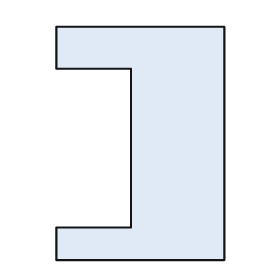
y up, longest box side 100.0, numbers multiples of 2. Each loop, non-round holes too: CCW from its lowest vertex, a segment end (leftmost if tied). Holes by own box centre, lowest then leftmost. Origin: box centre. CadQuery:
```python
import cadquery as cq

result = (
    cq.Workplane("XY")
    .moveTo(-36.0, -50.0)
    .lineTo(36.0, -50.0)
    .lineTo(36.0, 50.0)
    .lineTo(-36.0, 50.0)
    .lineTo(-36.0, 32.0)
    .lineTo(-4.0, 32.0)
    .lineTo(-4.0, -36.0)
    .lineTo(-36.0, -36.0)
    .close()
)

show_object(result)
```